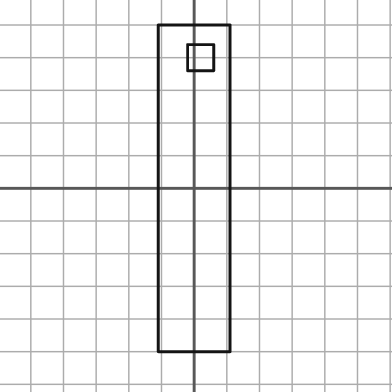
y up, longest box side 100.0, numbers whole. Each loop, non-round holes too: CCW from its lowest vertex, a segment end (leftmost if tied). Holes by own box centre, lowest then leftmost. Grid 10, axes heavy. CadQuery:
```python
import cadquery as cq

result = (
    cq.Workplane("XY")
    .moveTo(-11.0, -50.0)
    .lineTo(11.0, -50.0)
    .lineTo(11.0, 50.0)
    .lineTo(-11.0, 50.0)
    .close()
    .moveTo(-2.0, 36.0)
    .lineTo(6.0, 36.0)
    .lineTo(6.0, 44.0)
    .lineTo(-2.0, 44.0)
    .close()
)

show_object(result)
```